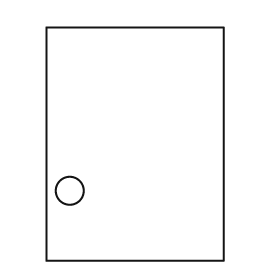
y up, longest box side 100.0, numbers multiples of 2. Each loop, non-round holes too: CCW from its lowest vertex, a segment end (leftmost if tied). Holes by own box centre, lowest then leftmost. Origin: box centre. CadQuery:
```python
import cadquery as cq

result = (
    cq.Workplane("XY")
    .moveTo(-38.0, -50.0)
    .lineTo(38.0, -50.0)
    .lineTo(38.0, 50.0)
    .lineTo(-38.0, 50.0)
    .close()
    .moveTo(-28.0, -20.0)
    .circle(6.0)
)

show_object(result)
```